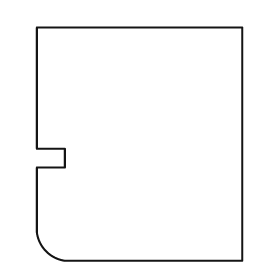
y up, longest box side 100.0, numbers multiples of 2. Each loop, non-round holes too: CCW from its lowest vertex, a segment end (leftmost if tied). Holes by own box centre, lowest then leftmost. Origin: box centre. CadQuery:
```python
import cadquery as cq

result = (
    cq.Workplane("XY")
    .moveTo(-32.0, -50.0)
    .lineTo(44.0, -50.0)
    .lineTo(44.0, 50.0)
    .lineTo(-44.0, 50.0)
    .lineTo(-44.0, -2.0)
    .lineTo(-32.0, -2.0)
    .lineTo(-32.0, -10.0)
    .lineTo(-44.0, -10.0)
    .lineTo(-44.0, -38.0)
    .threePointArc((-40.0, -46.0), (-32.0, -50.0))
    .close()
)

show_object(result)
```